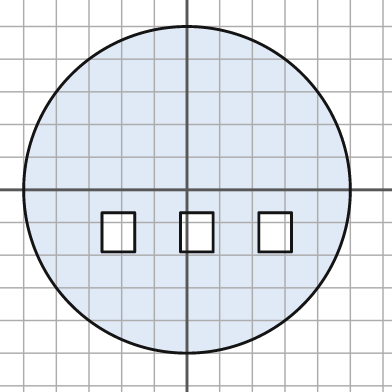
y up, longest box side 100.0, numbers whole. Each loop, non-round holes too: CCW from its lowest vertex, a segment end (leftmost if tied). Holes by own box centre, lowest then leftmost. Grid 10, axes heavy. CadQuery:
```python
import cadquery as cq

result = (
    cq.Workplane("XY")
    .moveTo(0.0, 0.0)
    .circle(50.0)
    .moveTo(-26.0, -19.0)
    .lineTo(-16.0, -19.0)
    .lineTo(-16.0, -7.0)
    .lineTo(-26.0, -7.0)
    .close()
    .moveTo(-2.0, -19.0)
    .lineTo(8.0, -19.0)
    .lineTo(8.0, -7.0)
    .lineTo(-2.0, -7.0)
    .close()
    .moveTo(22.0, -19.0)
    .lineTo(32.0, -19.0)
    .lineTo(32.0, -7.0)
    .lineTo(22.0, -7.0)
    .close()
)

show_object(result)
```